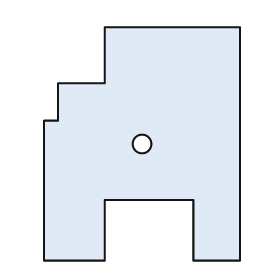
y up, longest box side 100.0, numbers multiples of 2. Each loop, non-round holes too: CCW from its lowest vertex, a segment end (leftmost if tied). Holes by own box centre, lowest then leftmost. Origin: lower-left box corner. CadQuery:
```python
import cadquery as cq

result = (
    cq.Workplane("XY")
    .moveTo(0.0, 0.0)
    .lineTo(26.0, 0.0)
    .lineTo(26.0, 26.0)
    .lineTo(64.0, 26.0)
    .lineTo(64.0, 0.0)
    .lineTo(84.0, 0.0)
    .lineTo(84.0, 100.0)
    .lineTo(26.0, 100.0)
    .lineTo(26.0, 76.0)
    .lineTo(6.0, 76.0)
    .lineTo(6.0, 60.0)
    .lineTo(0.0, 60.0)
    .close()
    .moveTo(42.0, 50.0)
    .circle(4.0)
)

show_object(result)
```